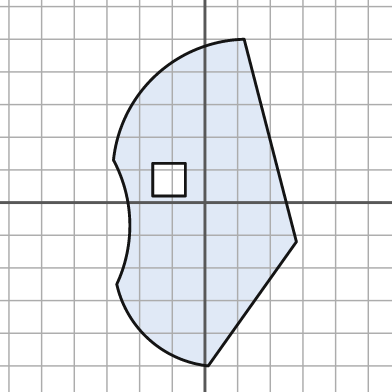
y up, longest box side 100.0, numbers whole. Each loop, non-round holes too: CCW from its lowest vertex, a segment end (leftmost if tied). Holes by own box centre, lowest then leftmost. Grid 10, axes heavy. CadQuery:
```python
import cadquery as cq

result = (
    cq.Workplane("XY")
    .moveTo(1.0, -50.0)
    .lineTo(28.0, -12.0)
    .lineTo(12.0, 50.0)
    .threePointArc((-15.0, 39.0), (-28.0, 13.0))
    .threePointArc((-23.0, -6.0), (-27.0, -25.0))
    .threePointArc((-17.0, -42.0), (1.0, -50.0))
    .close()
    .moveTo(-16.0, 2.0)
    .lineTo(-6.0, 2.0)
    .lineTo(-6.0, 12.0)
    .lineTo(-16.0, 12.0)
    .close()
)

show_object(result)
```